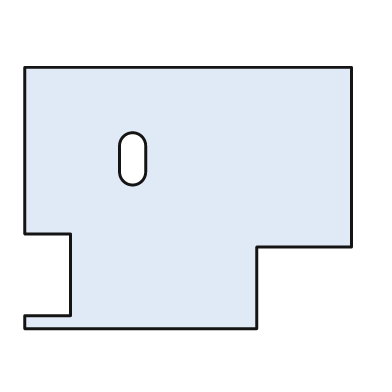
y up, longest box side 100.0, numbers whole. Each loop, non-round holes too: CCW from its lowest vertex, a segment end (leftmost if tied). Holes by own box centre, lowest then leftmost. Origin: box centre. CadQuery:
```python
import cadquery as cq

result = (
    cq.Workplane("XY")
    .moveTo(-50.0, -40.0)
    .lineTo(21.0, -40.0)
    .lineTo(21.0, -15.0)
    .lineTo(50.0, -15.0)
    .lineTo(50.0, 40.0)
    .lineTo(-50.0, 40.0)
    .lineTo(-50.0, -11.0)
    .lineTo(-36.0, -11.0)
    .lineTo(-36.0, -36.0)
    .lineTo(-50.0, -36.0)
    .close()
    .moveTo(-21.0, 8.0)
    .threePointArc((-17.0, 4.0), (-13.0, 8.0))
    .lineTo(-13.0, 16.0)
    .threePointArc((-17.0, 20.0), (-21.0, 16.0))
    .close()
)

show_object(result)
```